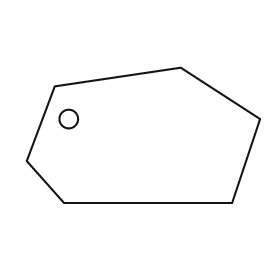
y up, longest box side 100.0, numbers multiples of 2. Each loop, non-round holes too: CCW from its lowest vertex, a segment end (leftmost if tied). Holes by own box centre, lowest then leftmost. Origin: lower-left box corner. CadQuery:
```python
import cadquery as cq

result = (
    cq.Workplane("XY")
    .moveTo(16.0, 0.0)
    .lineTo(88.0, 0.0)
    .lineTo(100.0, 36.0)
    .lineTo(66.0, 58.0)
    .lineTo(12.0, 50.0)
    .lineTo(0.0, 18.0)
    .close()
    .moveTo(18.0, 36.0)
    .circle(4.0)
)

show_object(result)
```